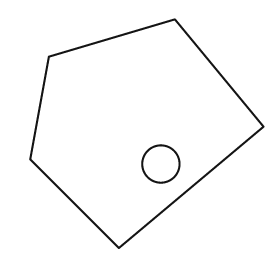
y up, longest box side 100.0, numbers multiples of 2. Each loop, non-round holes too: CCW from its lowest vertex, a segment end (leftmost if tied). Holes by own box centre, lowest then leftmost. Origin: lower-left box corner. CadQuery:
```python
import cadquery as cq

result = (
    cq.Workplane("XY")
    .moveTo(38.0, 0.0)
    .lineTo(100.0, 52.0)
    .lineTo(62.0, 98.0)
    .lineTo(8.0, 82.0)
    .lineTo(0.0, 38.0)
    .close()
    .moveTo(56.0, 36.0)
    .circle(8.0)
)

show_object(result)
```